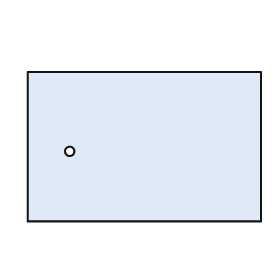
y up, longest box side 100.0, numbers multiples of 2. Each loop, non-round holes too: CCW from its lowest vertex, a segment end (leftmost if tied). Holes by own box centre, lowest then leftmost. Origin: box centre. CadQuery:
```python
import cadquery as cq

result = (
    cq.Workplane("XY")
    .moveTo(-50.0, -32.0)
    .lineTo(50.0, -32.0)
    .lineTo(50.0, 32.0)
    .lineTo(-50.0, 32.0)
    .close()
    .moveTo(-32.0, -2.0)
    .circle(2.0)
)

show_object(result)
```